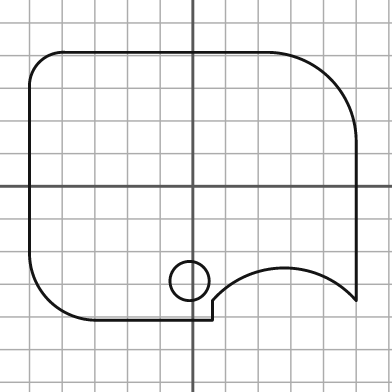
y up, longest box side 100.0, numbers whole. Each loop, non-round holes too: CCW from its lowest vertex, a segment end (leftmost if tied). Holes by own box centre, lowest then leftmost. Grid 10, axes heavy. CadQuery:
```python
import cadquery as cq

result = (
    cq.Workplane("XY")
    .moveTo(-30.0, -41.0)
    .lineTo(6.0, -41.0)
    .lineTo(6.0, -35.0)
    .threePointArc((28.0, -25.0), (50.0, -35.0))
    .lineTo(50.0, 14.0)
    .threePointArc((42.0, 33.0), (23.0, 41.0))
    .lineTo(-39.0, 41.0)
    .threePointArc((-47.0, 38.0), (-50.0, 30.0))
    .lineTo(-50.0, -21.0)
    .threePointArc((-44.0, -35.0), (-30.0, -41.0))
    .close()
    .moveTo(-1.0, -29.0)
    .circle(6.0)
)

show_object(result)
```